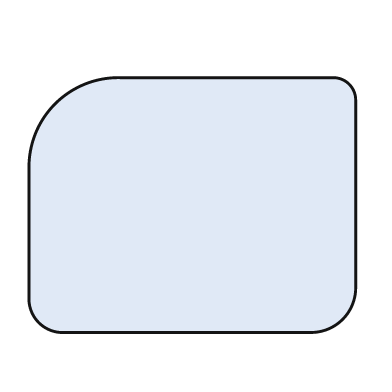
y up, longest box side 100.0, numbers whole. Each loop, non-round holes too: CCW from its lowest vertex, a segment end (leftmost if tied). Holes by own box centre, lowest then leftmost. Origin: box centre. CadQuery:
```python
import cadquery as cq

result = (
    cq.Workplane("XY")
    .moveTo(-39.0, -39.0)
    .lineTo(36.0, -39.0)
    .threePointArc((46.0, -35.0), (50.0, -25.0))
    .lineTo(50.0, 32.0)
    .threePointArc((48.0, 37.0), (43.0, 39.0))
    .lineTo(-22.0, 39.0)
    .threePointArc((-42.0, 31.0), (-50.0, 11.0))
    .lineTo(-50.0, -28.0)
    .threePointArc((-47.0, -36.0), (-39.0, -39.0))
    .close()
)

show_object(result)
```